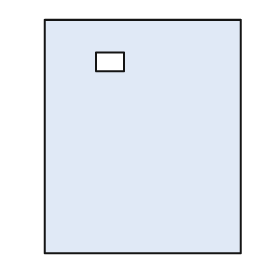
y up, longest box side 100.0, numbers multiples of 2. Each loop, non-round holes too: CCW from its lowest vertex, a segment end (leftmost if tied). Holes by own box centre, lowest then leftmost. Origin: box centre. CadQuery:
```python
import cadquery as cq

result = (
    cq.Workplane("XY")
    .moveTo(-42.0, -50.0)
    .lineTo(42.0, -50.0)
    .lineTo(42.0, 50.0)
    .lineTo(-42.0, 50.0)
    .close()
    .moveTo(-20.0, 28.0)
    .lineTo(-8.0, 28.0)
    .lineTo(-8.0, 36.0)
    .lineTo(-20.0, 36.0)
    .close()
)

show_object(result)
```